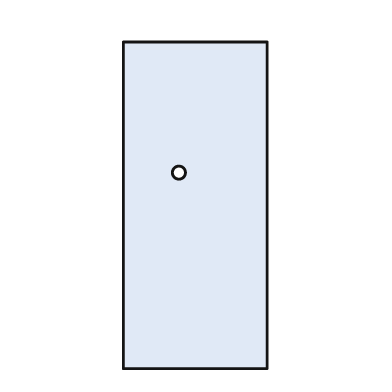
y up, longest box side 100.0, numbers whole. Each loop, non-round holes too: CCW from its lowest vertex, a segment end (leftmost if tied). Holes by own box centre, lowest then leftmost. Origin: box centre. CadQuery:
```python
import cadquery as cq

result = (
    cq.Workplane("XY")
    .moveTo(-22.0, -50.0)
    .lineTo(22.0, -50.0)
    .lineTo(22.0, 50.0)
    .lineTo(-22.0, 50.0)
    .close()
    .moveTo(-5.0, 10.0)
    .circle(2.0)
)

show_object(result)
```